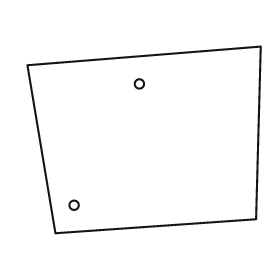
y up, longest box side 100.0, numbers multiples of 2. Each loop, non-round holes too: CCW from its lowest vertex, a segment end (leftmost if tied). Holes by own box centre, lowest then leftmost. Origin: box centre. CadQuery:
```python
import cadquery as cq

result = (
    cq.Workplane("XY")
    .moveTo(-38.0, -40.0)
    .lineTo(48.0, -34.0)
    .lineTo(50.0, 40.0)
    .lineTo(-50.0, 32.0)
    .close()
    .moveTo(-30.0, -28.0)
    .circle(2.0)
    .moveTo(-2.0, 24.0)
    .circle(2.0)
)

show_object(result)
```